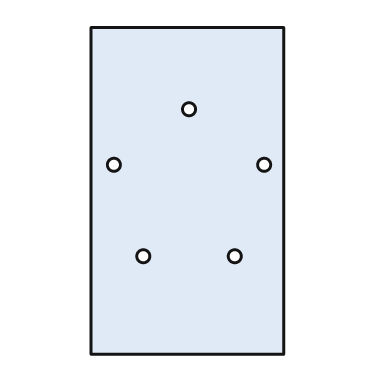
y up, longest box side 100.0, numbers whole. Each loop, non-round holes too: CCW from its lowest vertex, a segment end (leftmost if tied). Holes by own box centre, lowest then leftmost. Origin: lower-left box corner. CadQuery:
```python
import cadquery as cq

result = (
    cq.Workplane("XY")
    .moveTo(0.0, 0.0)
    .lineTo(59.0, 0.0)
    .lineTo(59.0, 100.0)
    .lineTo(0.0, 100.0)
    .close()
    .moveTo(16.0, 30.0)
    .circle(2.0)
    .moveTo(44.0, 30.0)
    .circle(2.0)
    .moveTo(7.0, 58.0)
    .circle(2.0)
    .moveTo(53.0, 58.0)
    .circle(2.0)
    .moveTo(30.0, 75.0)
    .circle(2.0)
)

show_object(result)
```